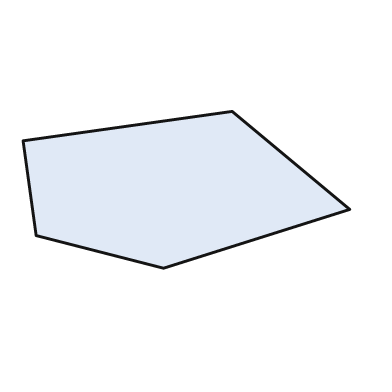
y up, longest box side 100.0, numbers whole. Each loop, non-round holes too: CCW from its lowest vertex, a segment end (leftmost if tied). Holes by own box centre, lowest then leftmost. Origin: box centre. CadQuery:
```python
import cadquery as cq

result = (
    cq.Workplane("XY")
    .moveTo(-7.0, -24.0)
    .lineTo(50.0, -6.0)
    .lineTo(14.0, 24.0)
    .lineTo(-50.0, 15.0)
    .lineTo(-46.0, -14.0)
    .close()
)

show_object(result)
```